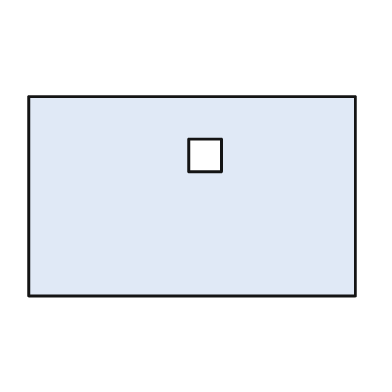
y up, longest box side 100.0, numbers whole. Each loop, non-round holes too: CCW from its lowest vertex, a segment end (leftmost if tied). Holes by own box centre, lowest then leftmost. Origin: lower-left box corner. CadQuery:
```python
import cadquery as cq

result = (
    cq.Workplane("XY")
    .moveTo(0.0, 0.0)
    .lineTo(100.0, 0.0)
    .lineTo(100.0, 61.0)
    .lineTo(0.0, 61.0)
    .close()
    .moveTo(49.0, 38.0)
    .lineTo(59.0, 38.0)
    .lineTo(59.0, 48.0)
    .lineTo(49.0, 48.0)
    .close()
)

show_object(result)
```